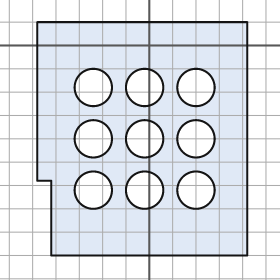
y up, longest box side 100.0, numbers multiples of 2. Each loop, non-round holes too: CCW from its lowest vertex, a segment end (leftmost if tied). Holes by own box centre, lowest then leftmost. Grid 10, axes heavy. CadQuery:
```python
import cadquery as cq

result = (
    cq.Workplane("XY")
    .moveTo(-42.0, -90.0)
    .lineTo(42.0, -90.0)
    .lineTo(42.0, 10.0)
    .lineTo(-48.0, 10.0)
    .lineTo(-48.0, -58.0)
    .lineTo(-42.0, -58.0)
    .close()
    .moveTo(-24.0, -62.0)
    .circle(8.0)
    .moveTo(-2.0, -62.0)
    .circle(8.0)
    .moveTo(20.0, -62.0)
    .circle(8.0)
    .moveTo(-24.0, -40.0)
    .circle(8.0)
    .moveTo(-2.0, -40.0)
    .circle(8.0)
    .moveTo(20.0, -40.0)
    .circle(8.0)
    .moveTo(-24.0, -18.0)
    .circle(8.0)
    .moveTo(-2.0, -18.0)
    .circle(8.0)
    .moveTo(20.0, -18.0)
    .circle(8.0)
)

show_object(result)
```